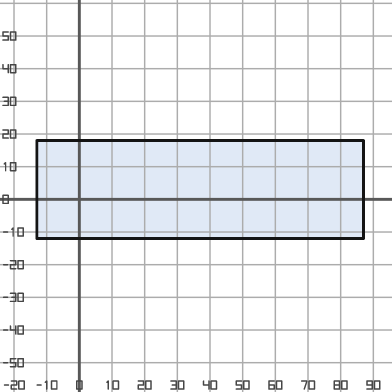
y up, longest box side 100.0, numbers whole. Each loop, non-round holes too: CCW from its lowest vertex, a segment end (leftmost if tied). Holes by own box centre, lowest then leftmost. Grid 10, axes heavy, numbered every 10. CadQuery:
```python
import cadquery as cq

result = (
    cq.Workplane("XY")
    .moveTo(-13.0, -12.0)
    .lineTo(87.0, -12.0)
    .lineTo(87.0, 18.0)
    .lineTo(-13.0, 18.0)
    .close()
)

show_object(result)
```